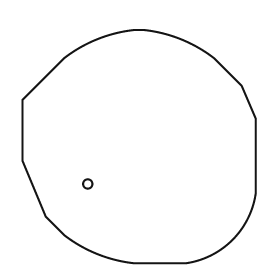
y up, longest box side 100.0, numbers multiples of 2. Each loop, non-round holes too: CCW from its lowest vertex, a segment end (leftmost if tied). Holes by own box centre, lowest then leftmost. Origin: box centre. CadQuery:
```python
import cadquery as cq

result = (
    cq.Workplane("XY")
    .moveTo(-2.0, -50.0)
    .lineTo(20.0, -50.0)
    .threePointArc((40.0, -40.0), (50.0, -20.0))
    .lineTo(50.0, 12.0)
    .lineTo(44.0, 26.0)
    .lineTo(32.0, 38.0)
    .threePointArc((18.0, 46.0), (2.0, 50.0))
    .lineTo(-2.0, 50.0)
    .threePointArc((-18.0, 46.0), (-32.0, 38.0))
    .lineTo(-50.0, 20.0)
    .lineTo(-50.0, -6.0)
    .lineTo(-40.0, -30.0)
    .lineTo(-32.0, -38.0)
    .threePointArc((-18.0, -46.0), (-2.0, -50.0))
    .close()
    .moveTo(-22.0, -16.0)
    .circle(2.0)
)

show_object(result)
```